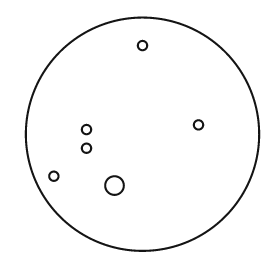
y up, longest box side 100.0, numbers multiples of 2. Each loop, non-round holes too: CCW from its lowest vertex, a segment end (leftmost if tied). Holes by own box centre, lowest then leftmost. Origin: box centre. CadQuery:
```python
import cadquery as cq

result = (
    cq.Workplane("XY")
    .moveTo(0.0, 0.0)
    .circle(50.0)
    .moveTo(-12.0, -22.0)
    .circle(4.0)
    .moveTo(-38.0, -18.0)
    .circle(2.0)
    .moveTo(-24.0, -6.0)
    .circle(2.0)
    .moveTo(-24.0, 2.0)
    .circle(2.0)
    .moveTo(24.0, 4.0)
    .circle(2.0)
    .moveTo(0.0, 38.0)
    .circle(2.0)
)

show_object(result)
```